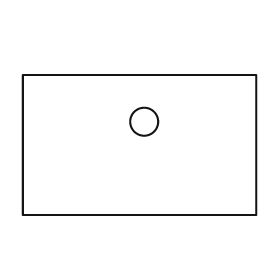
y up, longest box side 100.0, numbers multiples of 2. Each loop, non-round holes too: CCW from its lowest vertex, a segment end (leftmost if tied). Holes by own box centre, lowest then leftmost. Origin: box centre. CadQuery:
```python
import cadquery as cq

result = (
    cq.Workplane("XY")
    .moveTo(-50.0, -30.0)
    .lineTo(50.0, -30.0)
    .lineTo(50.0, 30.0)
    .lineTo(-50.0, 30.0)
    .close()
    .moveTo(2.0, 10.0)
    .circle(6.0)
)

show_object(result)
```